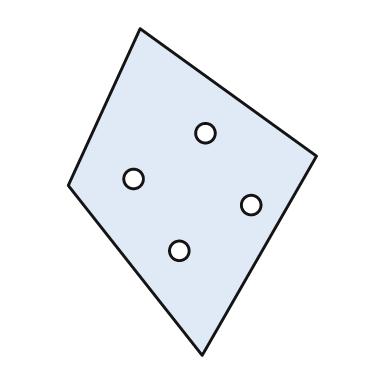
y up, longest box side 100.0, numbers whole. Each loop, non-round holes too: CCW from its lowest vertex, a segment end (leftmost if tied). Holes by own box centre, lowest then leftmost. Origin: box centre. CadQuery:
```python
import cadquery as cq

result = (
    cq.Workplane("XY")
    .moveTo(3.0, -50.0)
    .lineTo(38.0, 11.0)
    .lineTo(-16.0, 50.0)
    .lineTo(-38.0, 2.0)
    .close()
    .moveTo(-4.0, -18.0)
    .circle(3.0)
    .moveTo(18.0, -4.0)
    .circle(3.0)
    .moveTo(-18.0, 4.0)
    .circle(3.0)
    .moveTo(4.0, 18.0)
    .circle(3.0)
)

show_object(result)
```